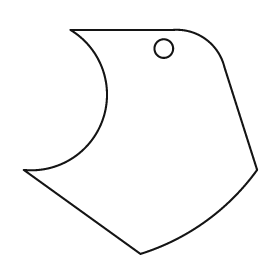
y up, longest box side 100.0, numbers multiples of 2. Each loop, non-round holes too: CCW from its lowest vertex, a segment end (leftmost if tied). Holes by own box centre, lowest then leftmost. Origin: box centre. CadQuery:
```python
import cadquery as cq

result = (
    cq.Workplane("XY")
    .moveTo(0.0, -48.0)
    .threePointArc((28.0, -34.0), (50.0, -12.0))
    .lineTo(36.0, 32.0)
    .threePointArc((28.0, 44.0), (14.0, 48.0))
    .lineTo(-30.0, 48.0)
    .threePointArc((-16.0, 10.0), (-50.0, -12.0))
    .close()
    .moveTo(10.0, 40.0)
    .circle(4.0)
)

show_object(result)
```